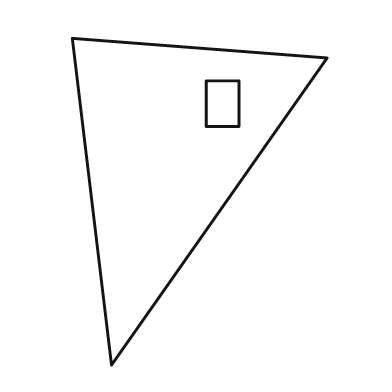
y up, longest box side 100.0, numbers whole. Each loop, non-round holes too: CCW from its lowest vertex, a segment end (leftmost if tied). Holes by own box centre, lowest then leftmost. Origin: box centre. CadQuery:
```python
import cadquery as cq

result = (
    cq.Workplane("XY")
    .moveTo(-27.0, -50.0)
    .lineTo(39.0, 44.0)
    .lineTo(-39.0, 50.0)
    .close()
    .moveTo(2.0, 23.0)
    .lineTo(12.0, 23.0)
    .lineTo(12.0, 37.0)
    .lineTo(2.0, 37.0)
    .close()
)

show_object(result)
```